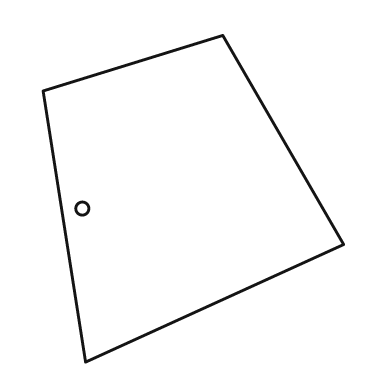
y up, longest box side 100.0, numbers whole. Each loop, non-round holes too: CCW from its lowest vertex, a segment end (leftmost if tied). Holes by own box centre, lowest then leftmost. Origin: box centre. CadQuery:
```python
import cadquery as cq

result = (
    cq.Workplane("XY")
    .moveTo(-33.0, -50.0)
    .lineTo(46.0, -14.0)
    .lineTo(9.0, 50.0)
    .lineTo(-46.0, 33.0)
    .close()
    .moveTo(-34.0, -3.0)
    .circle(2.0)
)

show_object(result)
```